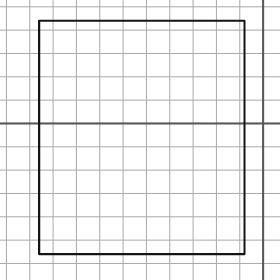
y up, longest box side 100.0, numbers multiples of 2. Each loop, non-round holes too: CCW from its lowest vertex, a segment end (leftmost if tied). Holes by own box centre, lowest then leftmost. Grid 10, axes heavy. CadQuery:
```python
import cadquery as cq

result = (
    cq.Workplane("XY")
    .moveTo(-96.0, -56.0)
    .lineTo(-8.0, -56.0)
    .lineTo(-8.0, 44.0)
    .lineTo(-96.0, 44.0)
    .close()
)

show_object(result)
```